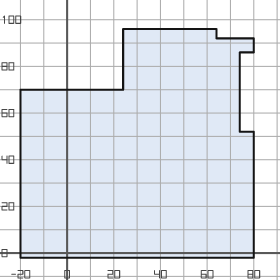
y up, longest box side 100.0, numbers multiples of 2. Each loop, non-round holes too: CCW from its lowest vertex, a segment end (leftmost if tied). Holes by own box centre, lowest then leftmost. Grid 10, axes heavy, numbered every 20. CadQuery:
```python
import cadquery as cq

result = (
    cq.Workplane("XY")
    .moveTo(-20.0, -2.0)
    .lineTo(80.0, -2.0)
    .lineTo(80.0, 52.0)
    .lineTo(74.0, 52.0)
    .lineTo(74.0, 86.0)
    .lineTo(80.0, 86.0)
    .lineTo(80.0, 92.0)
    .lineTo(64.0, 92.0)
    .lineTo(64.0, 96.0)
    .lineTo(24.0, 96.0)
    .lineTo(24.0, 70.0)
    .lineTo(-20.0, 70.0)
    .close()
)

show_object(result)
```